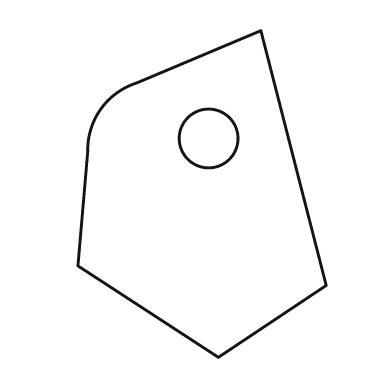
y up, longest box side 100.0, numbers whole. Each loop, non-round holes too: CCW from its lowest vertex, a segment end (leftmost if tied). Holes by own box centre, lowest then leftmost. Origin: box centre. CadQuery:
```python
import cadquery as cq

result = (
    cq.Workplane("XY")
    .moveTo(5.0, -50.0)
    .lineTo(38.0, -28.0)
    .lineTo(18.0, 50.0)
    .lineTo(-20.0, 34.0)
    .threePointArc((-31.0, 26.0), (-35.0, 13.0))
    .lineTo(-38.0, -22.0)
    .close()
    .moveTo(2.0, 17.0)
    .circle(9.0)
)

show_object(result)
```